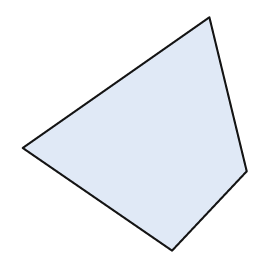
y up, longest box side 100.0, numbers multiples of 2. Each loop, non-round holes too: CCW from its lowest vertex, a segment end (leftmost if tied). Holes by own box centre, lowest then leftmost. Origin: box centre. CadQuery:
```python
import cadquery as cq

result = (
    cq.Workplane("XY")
    .moveTo(16.0, -50.0)
    .lineTo(48.0, -16.0)
    .lineTo(32.0, 50.0)
    .lineTo(-48.0, -6.0)
    .close()
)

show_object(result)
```